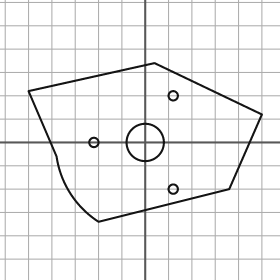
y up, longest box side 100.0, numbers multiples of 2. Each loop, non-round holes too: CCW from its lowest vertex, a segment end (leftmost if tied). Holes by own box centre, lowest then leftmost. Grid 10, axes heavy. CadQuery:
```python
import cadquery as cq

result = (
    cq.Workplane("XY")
    .moveTo(-20.0, -34.0)
    .lineTo(36.0, -20.0)
    .lineTo(50.0, 12.0)
    .lineTo(4.0, 34.0)
    .lineTo(-50.0, 22.0)
    .lineTo(-38.0, -6.0)
    .threePointArc((-32.0, -22.0), (-20.0, -34.0))
    .close()
    .moveTo(12.0, -20.0)
    .circle(2.0)
    .moveTo(-22.0, 0.0)
    .circle(2.0)
    .moveTo(0.0, 0.0)
    .circle(8.0)
    .moveTo(12.0, 20.0)
    .circle(2.0)
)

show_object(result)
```